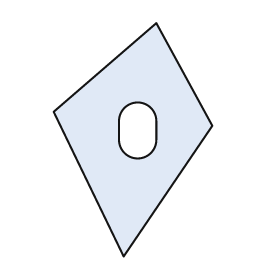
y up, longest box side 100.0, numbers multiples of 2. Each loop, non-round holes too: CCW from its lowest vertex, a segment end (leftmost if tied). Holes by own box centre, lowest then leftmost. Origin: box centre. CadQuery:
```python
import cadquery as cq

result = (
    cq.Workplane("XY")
    .moveTo(-4.0, -50.0)
    .lineTo(34.0, 6.0)
    .lineTo(10.0, 50.0)
    .lineTo(-34.0, 12.0)
    .close()
    .moveTo(-6.0, 0.0)
    .threePointArc((2.0, -8.0), (10.0, 0.0))
    .lineTo(10.0, 8.0)
    .threePointArc((2.0, 16.0), (-6.0, 8.0))
    .close()
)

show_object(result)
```